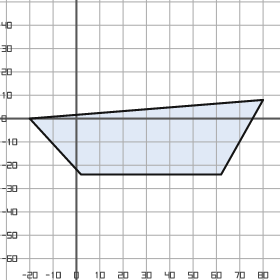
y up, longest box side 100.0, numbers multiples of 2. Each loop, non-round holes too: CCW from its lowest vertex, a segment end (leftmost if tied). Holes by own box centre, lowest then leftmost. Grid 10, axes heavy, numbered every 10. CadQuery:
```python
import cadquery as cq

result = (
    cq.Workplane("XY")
    .moveTo(2.0, -24.0)
    .lineTo(62.0, -24.0)
    .lineTo(80.0, 8.0)
    .lineTo(-20.0, 0.0)
    .close()
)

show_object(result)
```